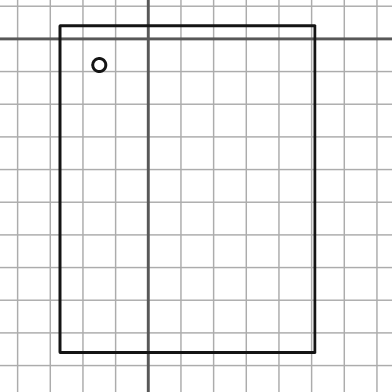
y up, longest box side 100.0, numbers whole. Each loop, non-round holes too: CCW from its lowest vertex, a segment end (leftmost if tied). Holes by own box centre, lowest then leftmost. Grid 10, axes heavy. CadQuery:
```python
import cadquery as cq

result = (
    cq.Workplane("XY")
    .moveTo(-27.0, -96.0)
    .lineTo(51.0, -96.0)
    .lineTo(51.0, 4.0)
    .lineTo(-27.0, 4.0)
    .close()
    .moveTo(-15.0, -8.0)
    .circle(2.0)
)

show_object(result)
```